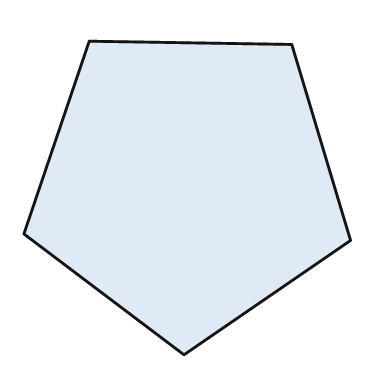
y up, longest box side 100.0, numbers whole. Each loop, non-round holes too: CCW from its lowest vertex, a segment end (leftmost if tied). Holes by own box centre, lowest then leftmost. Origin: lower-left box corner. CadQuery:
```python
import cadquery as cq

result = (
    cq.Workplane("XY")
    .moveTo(49.0, 0.0)
    .lineTo(100.0, 35.0)
    .lineTo(82.0, 95.0)
    .lineTo(20.0, 96.0)
    .lineTo(0.0, 37.0)
    .close()
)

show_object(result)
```